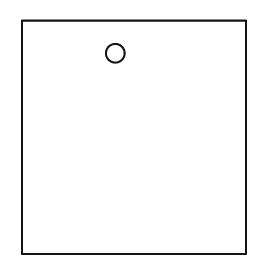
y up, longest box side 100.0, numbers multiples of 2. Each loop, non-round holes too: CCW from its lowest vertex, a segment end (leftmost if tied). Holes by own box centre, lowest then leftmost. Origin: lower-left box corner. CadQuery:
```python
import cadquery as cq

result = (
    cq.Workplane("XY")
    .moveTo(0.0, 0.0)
    .lineTo(96.0, 0.0)
    .lineTo(96.0, 100.0)
    .lineTo(0.0, 100.0)
    .close()
    .moveTo(40.0, 86.0)
    .circle(4.0)
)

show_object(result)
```